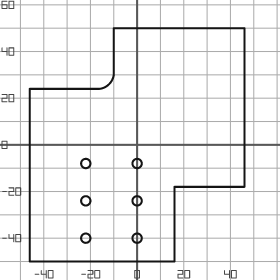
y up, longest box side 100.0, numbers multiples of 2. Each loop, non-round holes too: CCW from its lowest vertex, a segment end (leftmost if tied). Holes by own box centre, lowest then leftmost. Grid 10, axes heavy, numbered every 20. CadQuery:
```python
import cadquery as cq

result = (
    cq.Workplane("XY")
    .moveTo(-46.0, -50.0)
    .lineTo(16.0, -50.0)
    .lineTo(16.0, -18.0)
    .lineTo(46.0, -18.0)
    .lineTo(46.0, 50.0)
    .lineTo(-10.0, 50.0)
    .lineTo(-10.0, 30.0)
    .threePointArc((-12.0, 26.0), (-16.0, 24.0))
    .lineTo(-46.0, 24.0)
    .close()
    .moveTo(-22.0, -40.0)
    .circle(2.0)
    .moveTo(0.0, -40.0)
    .circle(2.0)
    .moveTo(-22.0, -24.0)
    .circle(2.0)
    .moveTo(0.0, -24.0)
    .circle(2.0)
    .moveTo(-22.0, -8.0)
    .circle(2.0)
    .moveTo(0.0, -8.0)
    .circle(2.0)
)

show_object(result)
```